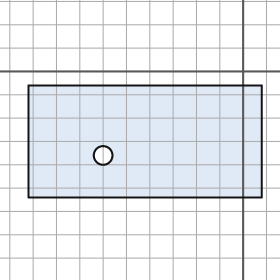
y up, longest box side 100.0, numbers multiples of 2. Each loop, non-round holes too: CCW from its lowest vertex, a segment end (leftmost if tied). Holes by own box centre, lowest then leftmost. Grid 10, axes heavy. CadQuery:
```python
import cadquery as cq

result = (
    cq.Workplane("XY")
    .moveTo(-92.0, -54.0)
    .lineTo(8.0, -54.0)
    .lineTo(8.0, -6.0)
    .lineTo(-92.0, -6.0)
    .close()
    .moveTo(-60.0, -36.0)
    .circle(4.0)
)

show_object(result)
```